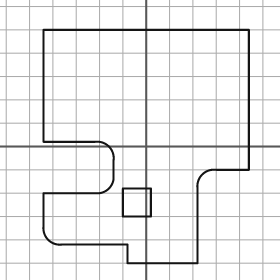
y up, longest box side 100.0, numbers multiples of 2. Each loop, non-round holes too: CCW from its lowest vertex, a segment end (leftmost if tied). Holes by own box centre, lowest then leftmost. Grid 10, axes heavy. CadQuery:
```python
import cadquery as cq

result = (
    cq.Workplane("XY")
    .moveTo(-8.0, -50.0)
    .lineTo(22.0, -50.0)
    .lineTo(22.0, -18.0)
    .threePointArc((24.0, -12.0), (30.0, -10.0))
    .lineTo(44.0, -10.0)
    .lineTo(44.0, 50.0)
    .lineTo(-44.0, 50.0)
    .lineTo(-44.0, 2.0)
    .lineTo(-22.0, 2.0)
    .threePointArc((-16.0, 0.0), (-14.0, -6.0))
    .lineTo(-14.0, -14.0)
    .threePointArc((-16.0, -18.0), (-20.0, -20.0))
    .lineTo(-44.0, -20.0)
    .lineTo(-44.0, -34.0)
    .threePointArc((-42.0, -40.0), (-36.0, -42.0))
    .lineTo(-8.0, -42.0)
    .close()
    .moveTo(-10.0, -30.0)
    .lineTo(2.0, -30.0)
    .lineTo(2.0, -18.0)
    .lineTo(-10.0, -18.0)
    .close()
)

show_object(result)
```